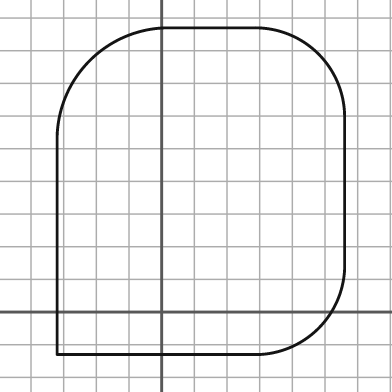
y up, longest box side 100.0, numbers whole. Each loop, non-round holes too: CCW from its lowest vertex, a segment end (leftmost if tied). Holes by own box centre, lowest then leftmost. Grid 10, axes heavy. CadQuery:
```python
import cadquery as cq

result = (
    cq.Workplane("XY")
    .moveTo(-32.0, -13.0)
    .lineTo(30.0, -13.0)
    .threePointArc((48.0, -5.0), (56.0, 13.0))
    .lineTo(56.0, 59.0)
    .threePointArc((48.0, 79.0), (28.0, 87.0))
    .lineTo(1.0, 87.0)
    .threePointArc((-22.0, 77.0), (-32.0, 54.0))
    .close()
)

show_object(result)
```